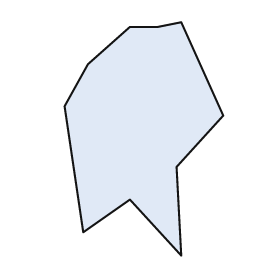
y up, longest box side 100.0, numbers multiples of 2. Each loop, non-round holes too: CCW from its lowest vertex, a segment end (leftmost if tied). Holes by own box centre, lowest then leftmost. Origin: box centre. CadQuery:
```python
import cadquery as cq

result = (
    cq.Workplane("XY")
    .moveTo(16.0, -50.0)
    .lineTo(14.0, -12.0)
    .lineTo(34.0, 10.0)
    .lineTo(16.0, 50.0)
    .lineTo(6.0, 48.0)
    .lineTo(-6.0, 48.0)
    .lineTo(-24.0, 32.0)
    .lineTo(-34.0, 14.0)
    .lineTo(-26.0, -40.0)
    .lineTo(-6.0, -26.0)
    .close()
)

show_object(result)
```